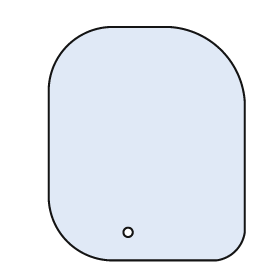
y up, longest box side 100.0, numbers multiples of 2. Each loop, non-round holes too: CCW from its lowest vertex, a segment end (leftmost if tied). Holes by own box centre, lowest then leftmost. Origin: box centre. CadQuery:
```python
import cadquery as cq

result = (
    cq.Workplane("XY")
    .moveTo(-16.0, -50.0)
    .lineTo(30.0, -50.0)
    .threePointArc((38.0, -46.0), (42.0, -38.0))
    .lineTo(42.0, 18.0)
    .threePointArc((32.0, 40.0), (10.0, 50.0))
    .lineTo(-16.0, 50.0)
    .threePointArc((-34.0, 42.0), (-42.0, 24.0))
    .lineTo(-42.0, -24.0)
    .threePointArc((-34.0, -42.0), (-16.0, -50.0))
    .close()
    .moveTo(-8.0, -38.0)
    .circle(2.0)
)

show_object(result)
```